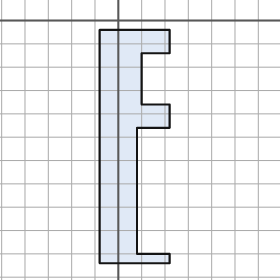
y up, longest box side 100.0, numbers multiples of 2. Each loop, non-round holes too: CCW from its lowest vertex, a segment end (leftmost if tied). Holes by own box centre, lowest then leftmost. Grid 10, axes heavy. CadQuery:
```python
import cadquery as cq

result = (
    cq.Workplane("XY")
    .moveTo(-8.0, -104.0)
    .lineTo(22.0, -104.0)
    .lineTo(22.0, -100.0)
    .lineTo(8.0, -100.0)
    .lineTo(8.0, -46.0)
    .lineTo(22.0, -46.0)
    .lineTo(22.0, -36.0)
    .lineTo(10.0, -36.0)
    .lineTo(10.0, -14.0)
    .lineTo(22.0, -14.0)
    .lineTo(22.0, -4.0)
    .lineTo(-8.0, -4.0)
    .close()
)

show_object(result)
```